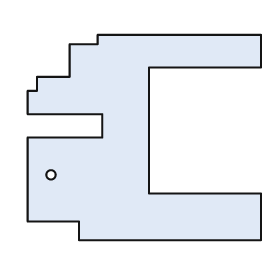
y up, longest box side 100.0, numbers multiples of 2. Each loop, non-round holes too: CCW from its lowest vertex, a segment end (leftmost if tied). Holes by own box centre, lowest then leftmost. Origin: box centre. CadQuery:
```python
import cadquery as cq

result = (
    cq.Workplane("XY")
    .moveTo(-28.0, -44.0)
    .lineTo(50.0, -44.0)
    .lineTo(50.0, -24.0)
    .lineTo(2.0, -24.0)
    .lineTo(2.0, 30.0)
    .lineTo(50.0, 30.0)
    .lineTo(50.0, 44.0)
    .lineTo(-20.0, 44.0)
    .lineTo(-20.0, 40.0)
    .lineTo(-32.0, 40.0)
    .lineTo(-32.0, 26.0)
    .lineTo(-46.0, 26.0)
    .lineTo(-46.0, 20.0)
    .lineTo(-50.0, 20.0)
    .lineTo(-50.0, 10.0)
    .lineTo(-18.0, 10.0)
    .lineTo(-18.0, 0.0)
    .lineTo(-50.0, 0.0)
    .lineTo(-50.0, -36.0)
    .lineTo(-28.0, -36.0)
    .close()
    .moveTo(-40.0, -16.0)
    .circle(2.0)
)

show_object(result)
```